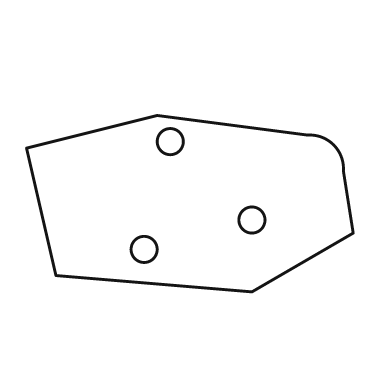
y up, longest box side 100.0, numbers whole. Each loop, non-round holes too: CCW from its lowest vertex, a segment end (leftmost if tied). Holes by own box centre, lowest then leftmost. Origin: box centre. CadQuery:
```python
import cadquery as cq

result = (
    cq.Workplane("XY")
    .moveTo(19.0, -27.0)
    .lineTo(50.0, -9.0)
    .lineTo(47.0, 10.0)
    .threePointArc((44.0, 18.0), (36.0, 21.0))
    .lineTo(-10.0, 27.0)
    .lineTo(-50.0, 17.0)
    .lineTo(-41.0, -22.0)
    .close()
    .moveTo(-14.0, -14.0)
    .circle(4.0)
    .moveTo(19.0, -5.0)
    .circle(4.0)
    .moveTo(-6.0, 19.0)
    .circle(4.0)
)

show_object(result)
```